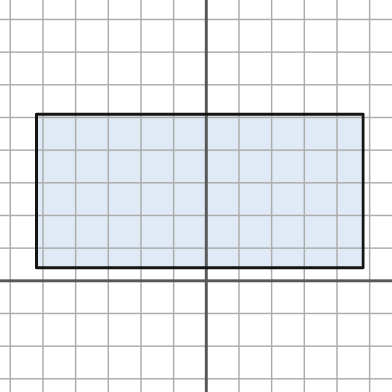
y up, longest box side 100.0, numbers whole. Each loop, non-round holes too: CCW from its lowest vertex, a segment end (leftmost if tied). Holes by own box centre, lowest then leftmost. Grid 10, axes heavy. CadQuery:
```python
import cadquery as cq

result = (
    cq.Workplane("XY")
    .moveTo(-52.0, 4.0)
    .lineTo(48.0, 4.0)
    .lineTo(48.0, 51.0)
    .lineTo(-52.0, 51.0)
    .close()
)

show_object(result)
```